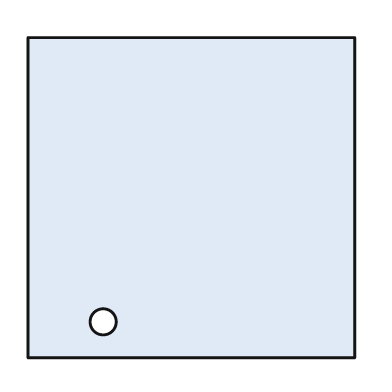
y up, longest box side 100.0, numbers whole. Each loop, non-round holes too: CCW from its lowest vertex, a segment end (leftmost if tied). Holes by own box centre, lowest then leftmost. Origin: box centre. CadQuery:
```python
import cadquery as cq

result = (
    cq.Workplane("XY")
    .moveTo(-50.0, -49.0)
    .lineTo(50.0, -49.0)
    .lineTo(50.0, 49.0)
    .lineTo(-50.0, 49.0)
    .close()
    .moveTo(-27.0, -38.0)
    .circle(4.0)
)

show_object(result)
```